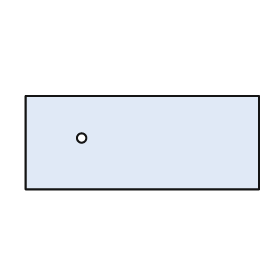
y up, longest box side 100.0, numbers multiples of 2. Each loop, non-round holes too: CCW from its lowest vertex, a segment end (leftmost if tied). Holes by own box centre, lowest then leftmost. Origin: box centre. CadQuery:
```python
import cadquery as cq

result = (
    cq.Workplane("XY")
    .moveTo(-50.0, -20.0)
    .lineTo(50.0, -20.0)
    .lineTo(50.0, 20.0)
    .lineTo(-50.0, 20.0)
    .close()
    .moveTo(-26.0, 2.0)
    .circle(2.0)
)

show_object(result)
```